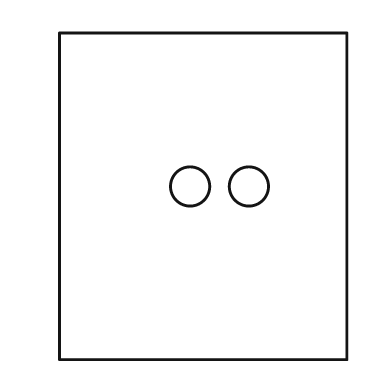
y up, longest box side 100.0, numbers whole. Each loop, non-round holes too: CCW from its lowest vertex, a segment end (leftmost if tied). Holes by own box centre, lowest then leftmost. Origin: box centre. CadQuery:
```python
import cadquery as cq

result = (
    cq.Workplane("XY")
    .moveTo(-44.0, -50.0)
    .lineTo(44.0, -50.0)
    .lineTo(44.0, 50.0)
    .lineTo(-44.0, 50.0)
    .close()
    .moveTo(-4.0, 3.0)
    .circle(6.0)
    .moveTo(14.0, 3.0)
    .circle(6.0)
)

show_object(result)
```